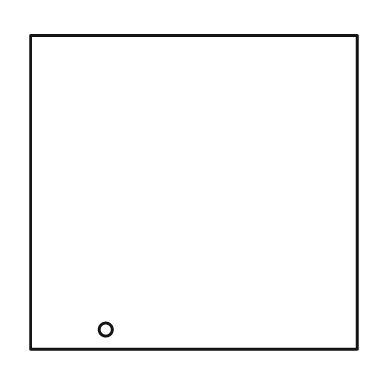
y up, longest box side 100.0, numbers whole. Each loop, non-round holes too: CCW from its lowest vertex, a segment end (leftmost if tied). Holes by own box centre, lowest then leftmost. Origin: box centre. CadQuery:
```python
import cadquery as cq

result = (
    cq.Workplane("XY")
    .moveTo(-50.0, -48.0)
    .lineTo(50.0, -48.0)
    .lineTo(50.0, 48.0)
    .lineTo(-50.0, 48.0)
    .close()
    .moveTo(-27.0, -42.0)
    .circle(2.0)
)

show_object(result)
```